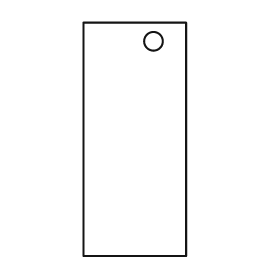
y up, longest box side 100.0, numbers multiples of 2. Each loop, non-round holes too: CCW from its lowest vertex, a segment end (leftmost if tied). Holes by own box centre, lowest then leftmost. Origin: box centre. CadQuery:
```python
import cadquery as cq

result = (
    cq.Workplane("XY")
    .moveTo(-22.0, -50.0)
    .lineTo(22.0, -50.0)
    .lineTo(22.0, 50.0)
    .lineTo(-22.0, 50.0)
    .close()
    .moveTo(8.0, 42.0)
    .circle(4.0)
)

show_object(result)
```